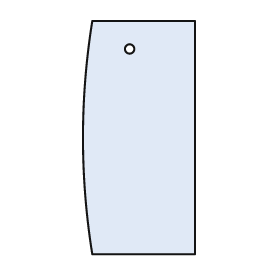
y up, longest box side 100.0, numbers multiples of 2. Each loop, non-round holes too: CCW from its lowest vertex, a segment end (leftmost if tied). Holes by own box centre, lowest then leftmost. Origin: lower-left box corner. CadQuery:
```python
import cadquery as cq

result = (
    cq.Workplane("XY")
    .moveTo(4.0, 0.0)
    .lineTo(48.0, 0.0)
    .lineTo(48.0, 100.0)
    .lineTo(4.0, 100.0)
    .threePointArc((0.0, 50.0), (4.0, 0.0))
    .close()
    .moveTo(20.0, 88.0)
    .circle(2.0)
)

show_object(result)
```